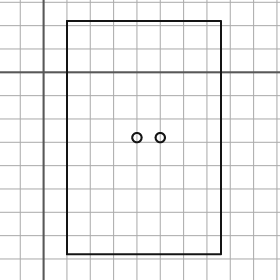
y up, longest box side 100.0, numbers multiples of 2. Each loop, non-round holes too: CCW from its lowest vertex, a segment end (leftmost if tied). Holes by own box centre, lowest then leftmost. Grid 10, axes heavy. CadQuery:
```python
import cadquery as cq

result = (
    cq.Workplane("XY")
    .moveTo(10.0, -78.0)
    .lineTo(76.0, -78.0)
    .lineTo(76.0, 22.0)
    .lineTo(10.0, 22.0)
    .close()
    .moveTo(40.0, -28.0)
    .circle(2.0)
    .moveTo(50.0, -28.0)
    .circle(2.0)
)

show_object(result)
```